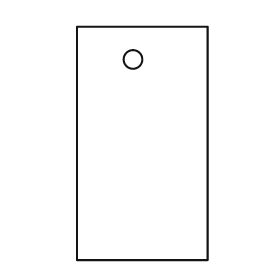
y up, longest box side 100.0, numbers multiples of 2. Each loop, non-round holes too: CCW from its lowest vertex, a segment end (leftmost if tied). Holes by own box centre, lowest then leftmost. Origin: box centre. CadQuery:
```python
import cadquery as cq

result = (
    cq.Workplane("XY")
    .moveTo(-28.0, -50.0)
    .lineTo(28.0, -50.0)
    .lineTo(28.0, 50.0)
    .lineTo(-28.0, 50.0)
    .close()
    .moveTo(-4.0, 36.0)
    .circle(4.0)
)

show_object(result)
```